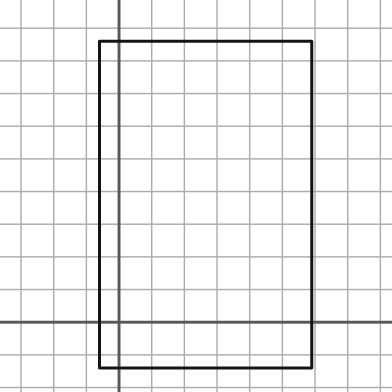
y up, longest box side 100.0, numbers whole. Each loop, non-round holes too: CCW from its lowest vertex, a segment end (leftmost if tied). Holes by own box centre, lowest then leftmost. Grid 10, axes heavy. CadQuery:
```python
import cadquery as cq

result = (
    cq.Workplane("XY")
    .moveTo(-6.0, -14.0)
    .lineTo(59.0, -14.0)
    .lineTo(59.0, 86.0)
    .lineTo(-6.0, 86.0)
    .close()
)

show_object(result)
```